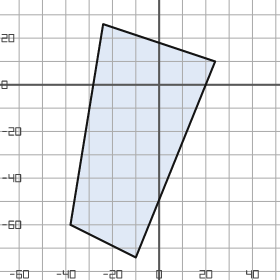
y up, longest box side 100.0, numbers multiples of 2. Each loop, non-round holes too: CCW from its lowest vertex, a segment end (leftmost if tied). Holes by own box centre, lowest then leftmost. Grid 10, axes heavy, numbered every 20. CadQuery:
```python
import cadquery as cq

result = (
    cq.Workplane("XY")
    .moveTo(-10.0, -74.0)
    .lineTo(24.0, 10.0)
    .lineTo(-24.0, 26.0)
    .lineTo(-38.0, -60.0)
    .close()
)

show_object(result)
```